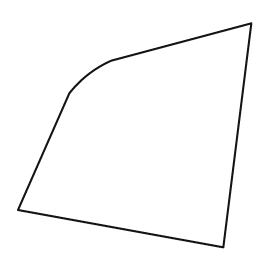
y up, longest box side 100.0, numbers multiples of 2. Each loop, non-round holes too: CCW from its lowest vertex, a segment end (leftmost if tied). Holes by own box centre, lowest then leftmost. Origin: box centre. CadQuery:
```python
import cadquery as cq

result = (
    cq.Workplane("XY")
    .moveTo(38.0, -48.0)
    .lineTo(50.0, 48.0)
    .lineTo(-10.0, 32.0)
    .threePointArc((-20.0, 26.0), (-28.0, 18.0))
    .lineTo(-50.0, -32.0)
    .close()
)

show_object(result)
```